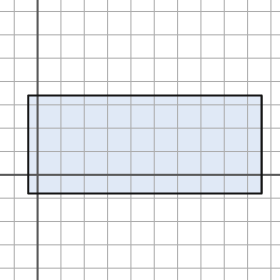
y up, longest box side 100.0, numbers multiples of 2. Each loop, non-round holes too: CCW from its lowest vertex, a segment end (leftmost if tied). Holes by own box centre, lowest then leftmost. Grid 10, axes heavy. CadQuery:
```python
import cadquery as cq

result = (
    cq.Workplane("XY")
    .moveTo(-4.0, -8.0)
    .lineTo(96.0, -8.0)
    .lineTo(96.0, 34.0)
    .lineTo(-4.0, 34.0)
    .close()
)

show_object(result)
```